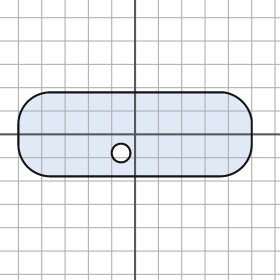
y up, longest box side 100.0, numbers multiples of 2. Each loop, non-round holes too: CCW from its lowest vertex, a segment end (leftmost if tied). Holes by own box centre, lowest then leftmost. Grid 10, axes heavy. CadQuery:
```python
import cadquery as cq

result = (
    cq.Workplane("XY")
    .moveTo(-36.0, -18.0)
    .lineTo(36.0, -18.0)
    .threePointArc((46.0, -14.0), (50.0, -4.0))
    .lineTo(50.0, 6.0)
    .threePointArc((46.0, 14.0), (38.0, 18.0))
    .lineTo(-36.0, 18.0)
    .threePointArc((-46.0, 14.0), (-50.0, 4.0))
    .lineTo(-50.0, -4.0)
    .threePointArc((-46.0, -14.0), (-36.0, -18.0))
    .close()
    .moveTo(-6.0, -8.0)
    .circle(4.0)
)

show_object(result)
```